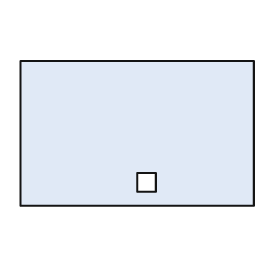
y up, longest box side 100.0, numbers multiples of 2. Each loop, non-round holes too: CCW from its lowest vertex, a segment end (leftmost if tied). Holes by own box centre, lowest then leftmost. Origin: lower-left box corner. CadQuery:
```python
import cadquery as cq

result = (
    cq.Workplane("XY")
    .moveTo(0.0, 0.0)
    .lineTo(100.0, 0.0)
    .lineTo(100.0, 62.0)
    .lineTo(0.0, 62.0)
    .close()
    .moveTo(50.0, 6.0)
    .lineTo(58.0, 6.0)
    .lineTo(58.0, 14.0)
    .lineTo(50.0, 14.0)
    .close()
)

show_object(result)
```